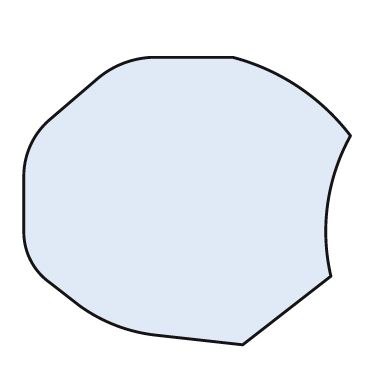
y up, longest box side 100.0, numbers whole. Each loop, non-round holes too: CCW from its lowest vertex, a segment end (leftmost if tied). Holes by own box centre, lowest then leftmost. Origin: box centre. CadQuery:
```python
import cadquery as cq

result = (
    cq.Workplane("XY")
    .moveTo(17.0, -44.0)
    .lineTo(44.0, -23.0)
    .threePointArc((43.0, -1.0), (50.0, 20.0))
    .threePointArc((34.0, 35.0), (14.0, 44.0))
    .lineTo(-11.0, 44.0)
    .threePointArc((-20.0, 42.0), (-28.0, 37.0))
    .lineTo(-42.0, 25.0)
    .threePointArc((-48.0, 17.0), (-50.0, 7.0))
    .lineTo(-50.0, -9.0)
    .threePointArc((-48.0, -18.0), (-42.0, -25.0))
    .lineTo(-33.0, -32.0)
    .threePointArc((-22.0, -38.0), (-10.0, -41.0))
    .close()
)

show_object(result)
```